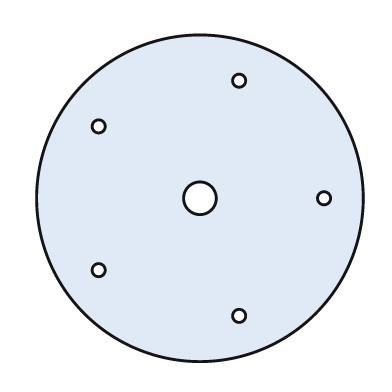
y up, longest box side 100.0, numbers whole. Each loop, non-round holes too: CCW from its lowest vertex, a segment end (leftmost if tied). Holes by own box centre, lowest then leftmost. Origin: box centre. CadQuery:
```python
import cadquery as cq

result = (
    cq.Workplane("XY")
    .moveTo(0.0, 0.0)
    .circle(50.0)
    .moveTo(12.0, -36.0)
    .circle(2.0)
    .moveTo(-31.0, -22.0)
    .circle(2.0)
    .moveTo(0.0, 0.0)
    .circle(5.0)
    .moveTo(38.0, 0.0)
    .circle(2.0)
    .moveTo(-31.0, 22.0)
    .circle(2.0)
    .moveTo(12.0, 36.0)
    .circle(2.0)
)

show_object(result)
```